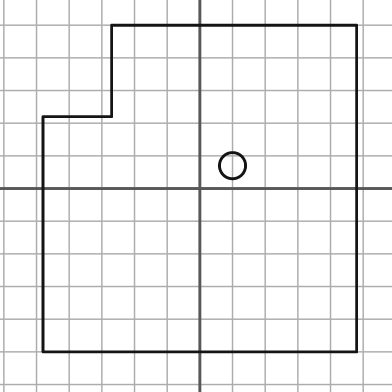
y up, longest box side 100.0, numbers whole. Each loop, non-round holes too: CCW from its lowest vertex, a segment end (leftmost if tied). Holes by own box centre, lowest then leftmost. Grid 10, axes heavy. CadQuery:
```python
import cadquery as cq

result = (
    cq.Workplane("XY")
    .moveTo(-48.0, -50.0)
    .lineTo(48.0, -50.0)
    .lineTo(48.0, 50.0)
    .lineTo(-27.0, 50.0)
    .lineTo(-27.0, 22.0)
    .lineTo(-48.0, 22.0)
    .close()
    .moveTo(10.0, 7.0)
    .circle(4.0)
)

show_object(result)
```